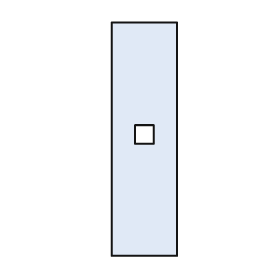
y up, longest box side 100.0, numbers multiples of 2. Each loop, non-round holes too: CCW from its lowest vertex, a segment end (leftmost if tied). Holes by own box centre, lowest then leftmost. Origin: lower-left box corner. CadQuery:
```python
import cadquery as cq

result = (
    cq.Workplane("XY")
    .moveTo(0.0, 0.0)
    .lineTo(28.0, 0.0)
    .lineTo(28.0, 100.0)
    .lineTo(0.0, 100.0)
    .close()
    .moveTo(10.0, 48.0)
    .lineTo(18.0, 48.0)
    .lineTo(18.0, 56.0)
    .lineTo(10.0, 56.0)
    .close()
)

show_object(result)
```